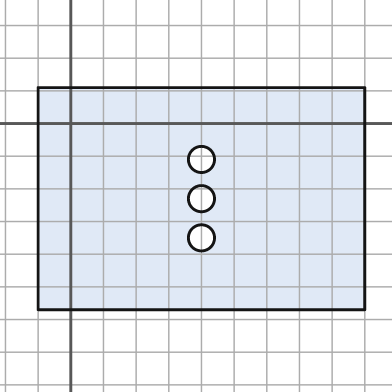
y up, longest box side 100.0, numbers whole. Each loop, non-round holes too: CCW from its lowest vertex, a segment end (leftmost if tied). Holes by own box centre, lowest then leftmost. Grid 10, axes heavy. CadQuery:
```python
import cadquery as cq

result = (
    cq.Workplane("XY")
    .moveTo(-10.0, -57.0)
    .lineTo(90.0, -57.0)
    .lineTo(90.0, 11.0)
    .lineTo(-10.0, 11.0)
    .close()
    .moveTo(40.0, -35.0)
    .circle(4.0)
    .moveTo(40.0, -23.0)
    .circle(4.0)
    .moveTo(40.0, -11.0)
    .circle(4.0)
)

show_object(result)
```